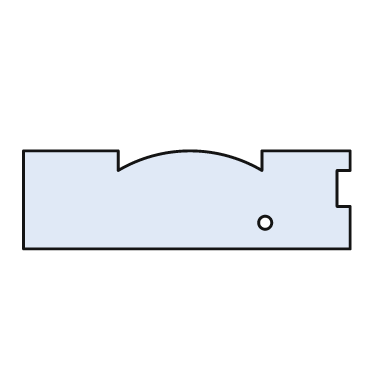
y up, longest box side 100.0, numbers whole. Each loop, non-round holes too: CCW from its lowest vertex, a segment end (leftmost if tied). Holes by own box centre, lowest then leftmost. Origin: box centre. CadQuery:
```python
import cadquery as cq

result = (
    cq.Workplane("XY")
    .moveTo(-50.0, -15.0)
    .lineTo(50.0, -15.0)
    .lineTo(50.0, -2.0)
    .lineTo(46.0, -2.0)
    .lineTo(46.0, 9.0)
    .lineTo(50.0, 9.0)
    .lineTo(50.0, 15.0)
    .lineTo(23.0, 15.0)
    .lineTo(23.0, 9.0)
    .threePointArc((1.0, 15.0), (-21.0, 9.0))
    .lineTo(-21.0, 15.0)
    .lineTo(-50.0, 15.0)
    .close()
    .moveTo(24.0, -7.0)
    .circle(2.0)
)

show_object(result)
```